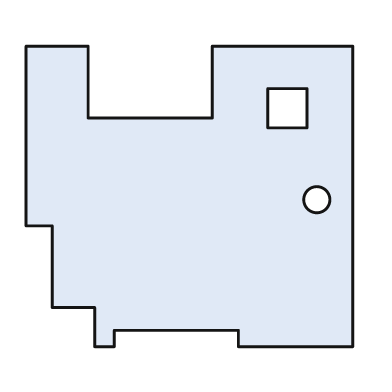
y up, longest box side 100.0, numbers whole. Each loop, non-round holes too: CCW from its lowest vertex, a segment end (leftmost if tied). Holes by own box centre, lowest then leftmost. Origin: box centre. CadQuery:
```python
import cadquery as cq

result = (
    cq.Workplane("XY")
    .moveTo(-29.0, -46.0)
    .lineTo(-23.0, -46.0)
    .lineTo(-23.0, -41.0)
    .lineTo(15.0, -41.0)
    .lineTo(15.0, -46.0)
    .lineTo(50.0, -46.0)
    .lineTo(50.0, 46.0)
    .lineTo(7.0, 46.0)
    .lineTo(7.0, 24.0)
    .lineTo(-31.0, 24.0)
    .lineTo(-31.0, 46.0)
    .lineTo(-50.0, 46.0)
    .lineTo(-50.0, -9.0)
    .lineTo(-42.0, -9.0)
    .lineTo(-42.0, -34.0)
    .lineTo(-29.0, -34.0)
    .close()
    .moveTo(39.0, -1.0)
    .circle(4.0)
    .moveTo(24.0, 21.0)
    .lineTo(36.0, 21.0)
    .lineTo(36.0, 33.0)
    .lineTo(24.0, 33.0)
    .close()
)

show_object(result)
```